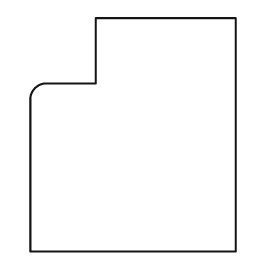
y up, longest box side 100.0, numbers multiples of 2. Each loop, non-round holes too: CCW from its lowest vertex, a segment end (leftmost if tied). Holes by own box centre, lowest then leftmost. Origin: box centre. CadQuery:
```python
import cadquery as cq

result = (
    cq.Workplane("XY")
    .moveTo(-44.0, -50.0)
    .lineTo(44.0, -50.0)
    .lineTo(44.0, 50.0)
    .lineTo(-16.0, 50.0)
    .lineTo(-16.0, 22.0)
    .lineTo(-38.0, 22.0)
    .threePointArc((-42.0, 20.0), (-44.0, 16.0))
    .close()
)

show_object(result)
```